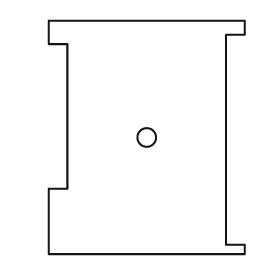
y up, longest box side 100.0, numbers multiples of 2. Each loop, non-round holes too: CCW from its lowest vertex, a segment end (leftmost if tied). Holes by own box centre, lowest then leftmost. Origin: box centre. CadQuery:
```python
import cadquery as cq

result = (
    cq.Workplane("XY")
    .moveTo(-42.0, -50.0)
    .lineTo(42.0, -50.0)
    .lineTo(42.0, -46.0)
    .lineTo(34.0, -46.0)
    .lineTo(34.0, 44.0)
    .lineTo(42.0, 44.0)
    .lineTo(42.0, 50.0)
    .lineTo(-42.0, 50.0)
    .lineTo(-42.0, 40.0)
    .lineTo(-34.0, 40.0)
    .lineTo(-34.0, -22.0)
    .lineTo(-42.0, -22.0)
    .close()
    .moveTo(0.0, 0.0)
    .circle(4.0)
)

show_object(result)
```